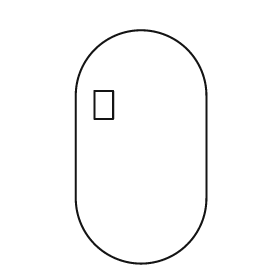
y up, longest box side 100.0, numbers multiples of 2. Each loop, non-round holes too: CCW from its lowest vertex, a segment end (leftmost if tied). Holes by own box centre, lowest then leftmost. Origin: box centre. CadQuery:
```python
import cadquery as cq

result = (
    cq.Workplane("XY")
    .moveTo(-28.0, -22.0)
    .threePointArc((0.0, -50.0), (28.0, -22.0))
    .lineTo(28.0, 22.0)
    .threePointArc((0.0, 50.0), (-28.0, 22.0))
    .close()
    .moveTo(-20.0, 12.0)
    .lineTo(-12.0, 12.0)
    .lineTo(-12.0, 24.0)
    .lineTo(-20.0, 24.0)
    .close()
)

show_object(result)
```